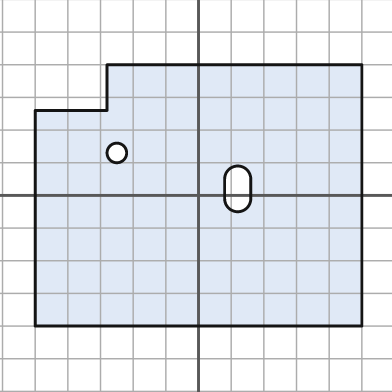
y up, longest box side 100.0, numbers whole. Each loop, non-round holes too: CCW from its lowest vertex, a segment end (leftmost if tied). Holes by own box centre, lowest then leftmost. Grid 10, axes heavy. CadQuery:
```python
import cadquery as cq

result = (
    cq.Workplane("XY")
    .moveTo(-50.0, -40.0)
    .lineTo(50.0, -40.0)
    .lineTo(50.0, 40.0)
    .lineTo(-28.0, 40.0)
    .lineTo(-28.0, 26.0)
    .lineTo(-50.0, 26.0)
    .close()
    .moveTo(8.0, -1.0)
    .threePointArc((12.0, -5.0), (16.0, -1.0))
    .lineTo(16.0, 5.0)
    .threePointArc((12.0, 9.0), (8.0, 5.0))
    .close()
    .moveTo(-25.0, 13.0)
    .circle(3.0)
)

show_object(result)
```